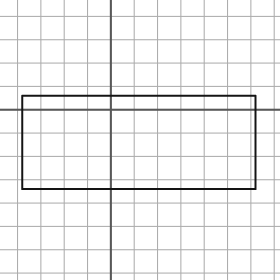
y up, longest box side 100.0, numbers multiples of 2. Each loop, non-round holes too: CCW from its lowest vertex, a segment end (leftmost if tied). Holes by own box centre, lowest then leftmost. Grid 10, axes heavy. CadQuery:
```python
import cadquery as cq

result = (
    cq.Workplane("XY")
    .moveTo(-38.0, -34.0)
    .lineTo(62.0, -34.0)
    .lineTo(62.0, 6.0)
    .lineTo(-38.0, 6.0)
    .close()
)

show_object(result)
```